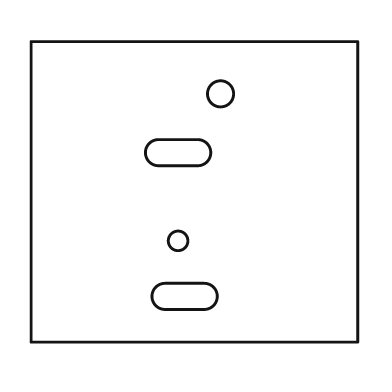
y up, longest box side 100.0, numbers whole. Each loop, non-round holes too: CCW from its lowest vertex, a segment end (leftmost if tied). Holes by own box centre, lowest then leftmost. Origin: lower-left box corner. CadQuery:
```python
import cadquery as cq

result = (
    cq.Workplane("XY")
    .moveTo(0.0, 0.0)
    .lineTo(100.0, 0.0)
    .lineTo(100.0, 92.0)
    .lineTo(0.0, 92.0)
    .close()
    .moveTo(41.0, 10.0)
    .lineTo(53.0, 10.0)
    .threePointArc((57.0, 14.0), (53.0, 18.0))
    .lineTo(41.0, 18.0)
    .threePointArc((37.0, 14.0), (41.0, 10.0))
    .close()
    .moveTo(45.0, 31.0)
    .circle(3.0)
    .moveTo(39.0, 54.0)
    .lineTo(51.0, 54.0)
    .threePointArc((55.0, 58.0), (51.0, 62.0))
    .lineTo(39.0, 62.0)
    .threePointArc((35.0, 58.0), (39.0, 54.0))
    .close()
    .moveTo(58.0, 76.0)
    .circle(4.0)
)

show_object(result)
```